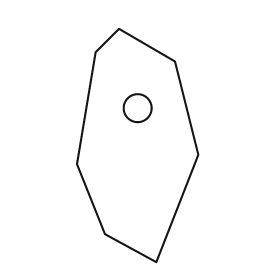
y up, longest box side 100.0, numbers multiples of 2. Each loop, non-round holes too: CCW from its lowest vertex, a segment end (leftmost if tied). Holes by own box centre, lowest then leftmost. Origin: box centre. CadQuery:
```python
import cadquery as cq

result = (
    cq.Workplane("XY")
    .moveTo(8.0, -50.0)
    .lineTo(26.0, -4.0)
    .lineTo(16.0, 36.0)
    .lineTo(-8.0, 50.0)
    .lineTo(-18.0, 40.0)
    .lineTo(-26.0, -8.0)
    .lineTo(-14.0, -38.0)
    .close()
    .moveTo(0.0, 16.0)
    .circle(6.0)
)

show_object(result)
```